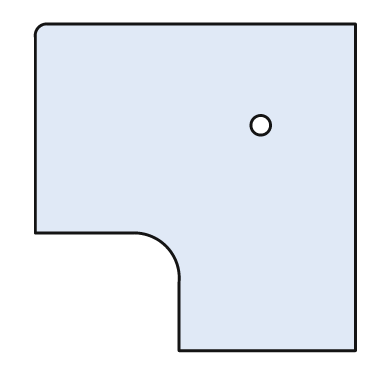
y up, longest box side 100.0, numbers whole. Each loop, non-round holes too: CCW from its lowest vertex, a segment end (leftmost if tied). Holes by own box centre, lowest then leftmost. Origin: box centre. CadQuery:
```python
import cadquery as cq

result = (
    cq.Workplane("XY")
    .moveTo(-5.0, -50.0)
    .lineTo(49.0, -50.0)
    .lineTo(49.0, 50.0)
    .lineTo(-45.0, 50.0)
    .threePointArc((-48.0, 49.0), (-49.0, 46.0))
    .lineTo(-49.0, -14.0)
    .lineTo(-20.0, -14.0)
    .threePointArc((-9.0, -18.0), (-5.0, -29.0))
    .close()
    .moveTo(20.0, 19.0)
    .circle(3.0)
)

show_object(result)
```